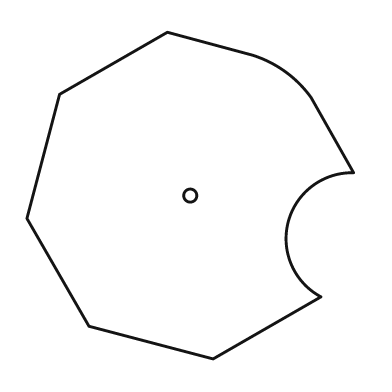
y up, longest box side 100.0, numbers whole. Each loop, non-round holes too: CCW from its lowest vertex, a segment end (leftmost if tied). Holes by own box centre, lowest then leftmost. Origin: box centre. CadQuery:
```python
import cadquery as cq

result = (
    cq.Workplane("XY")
    .moveTo(7.0, -50.0)
    .lineTo(40.0, -31.0)
    .threePointArc((30.0, -8.0), (50.0, 7.0))
    .lineTo(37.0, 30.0)
    .threePointArc((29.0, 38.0), (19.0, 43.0))
    .lineTo(-7.0, 50.0)
    .lineTo(-40.0, 31.0)
    .lineTo(-50.0, -7.0)
    .lineTo(-31.0, -40.0)
    .close()
    .moveTo(0.0, 0.0)
    .circle(2.0)
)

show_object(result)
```